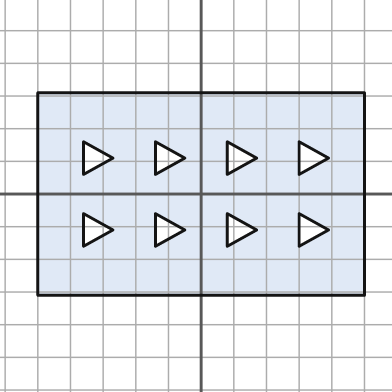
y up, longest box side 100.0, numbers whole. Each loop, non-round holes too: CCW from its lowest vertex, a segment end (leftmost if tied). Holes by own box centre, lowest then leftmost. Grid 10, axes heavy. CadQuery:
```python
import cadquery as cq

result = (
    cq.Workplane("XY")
    .moveTo(-50.0, -31.0)
    .lineTo(50.0, -31.0)
    .lineTo(50.0, 31.0)
    .lineTo(-50.0, 31.0)
    .close()
    .moveTo(-36.0, -16.0)
    .lineTo(-27.0, -11.0)
    .lineTo(-36.0, -6.0)
    .close()
    .moveTo(-14.0, -16.0)
    .lineTo(-5.0, -11.0)
    .lineTo(-14.0, -6.0)
    .close()
    .moveTo(8.0, -16.0)
    .lineTo(17.0, -11.0)
    .lineTo(8.0, -6.0)
    .close()
    .moveTo(30.0, -16.0)
    .lineTo(39.0, -11.0)
    .lineTo(30.0, -6.0)
    .close()
    .moveTo(-36.0, 6.0)
    .lineTo(-27.0, 11.0)
    .lineTo(-36.0, 16.0)
    .close()
    .moveTo(-14.0, 6.0)
    .lineTo(-5.0, 11.0)
    .lineTo(-14.0, 16.0)
    .close()
    .moveTo(8.0, 6.0)
    .lineTo(17.0, 11.0)
    .lineTo(8.0, 16.0)
    .close()
    .moveTo(30.0, 6.0)
    .lineTo(39.0, 11.0)
    .lineTo(30.0, 16.0)
    .close()
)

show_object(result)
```